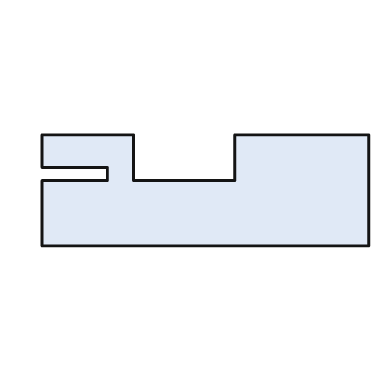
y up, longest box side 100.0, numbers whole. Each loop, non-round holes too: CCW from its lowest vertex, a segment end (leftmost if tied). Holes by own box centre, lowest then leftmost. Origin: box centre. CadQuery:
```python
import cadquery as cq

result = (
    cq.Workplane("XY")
    .moveTo(-50.0, -17.0)
    .lineTo(50.0, -17.0)
    .lineTo(50.0, 17.0)
    .lineTo(9.0, 17.0)
    .lineTo(9.0, 3.0)
    .lineTo(-22.0, 3.0)
    .lineTo(-22.0, 17.0)
    .lineTo(-50.0, 17.0)
    .lineTo(-50.0, 7.0)
    .lineTo(-30.0, 7.0)
    .lineTo(-30.0, 3.0)
    .lineTo(-50.0, 3.0)
    .close()
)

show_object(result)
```